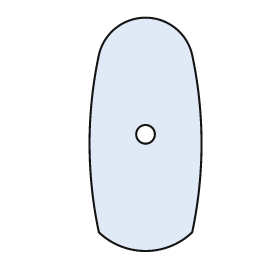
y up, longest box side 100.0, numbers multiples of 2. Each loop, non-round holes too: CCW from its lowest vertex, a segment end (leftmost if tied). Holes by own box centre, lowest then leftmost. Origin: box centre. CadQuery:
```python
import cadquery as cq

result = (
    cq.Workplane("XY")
    .moveTo(-20.0, -42.0)
    .threePointArc((0.0, -50.0), (20.0, -42.0))
    .threePointArc((24.0, -4.0), (20.0, 34.0))
    .threePointArc((0.0, 50.0), (-20.0, 34.0))
    .threePointArc((-24.0, -4.0), (-20.0, -42.0))
    .close()
    .moveTo(0.0, 0.0)
    .circle(4.0)
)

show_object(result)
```